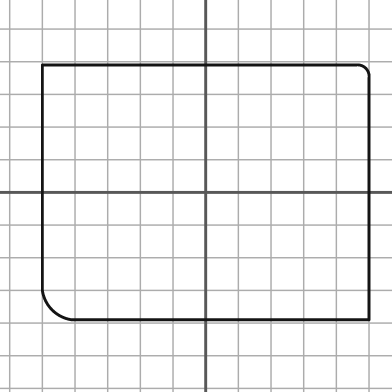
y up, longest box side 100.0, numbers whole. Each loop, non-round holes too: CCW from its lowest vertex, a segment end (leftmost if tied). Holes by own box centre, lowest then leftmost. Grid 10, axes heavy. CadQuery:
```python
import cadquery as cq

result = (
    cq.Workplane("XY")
    .moveTo(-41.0, -39.0)
    .lineTo(50.0, -39.0)
    .lineTo(50.0, 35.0)
    .threePointArc((49.0, 38.0), (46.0, 39.0))
    .lineTo(-50.0, 39.0)
    .lineTo(-50.0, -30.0)
    .threePointArc((-47.0, -36.0), (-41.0, -39.0))
    .close()
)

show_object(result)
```